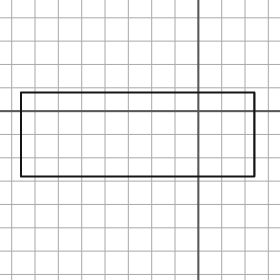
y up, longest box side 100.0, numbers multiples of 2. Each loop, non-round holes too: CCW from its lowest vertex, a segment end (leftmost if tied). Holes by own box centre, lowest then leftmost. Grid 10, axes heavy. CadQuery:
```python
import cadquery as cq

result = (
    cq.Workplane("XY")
    .moveTo(-76.0, -28.0)
    .lineTo(24.0, -28.0)
    .lineTo(24.0, 8.0)
    .lineTo(-76.0, 8.0)
    .close()
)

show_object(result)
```